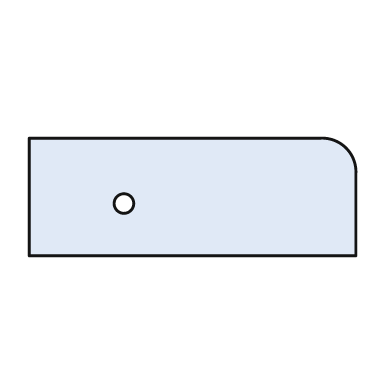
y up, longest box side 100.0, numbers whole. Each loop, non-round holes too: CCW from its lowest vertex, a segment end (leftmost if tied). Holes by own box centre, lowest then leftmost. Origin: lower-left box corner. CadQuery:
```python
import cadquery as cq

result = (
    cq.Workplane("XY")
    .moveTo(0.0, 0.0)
    .lineTo(100.0, 0.0)
    .lineTo(100.0, 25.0)
    .threePointArc((97.0, 33.0), (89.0, 36.0))
    .lineTo(0.0, 36.0)
    .close()
    .moveTo(29.0, 16.0)
    .circle(3.0)
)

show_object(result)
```